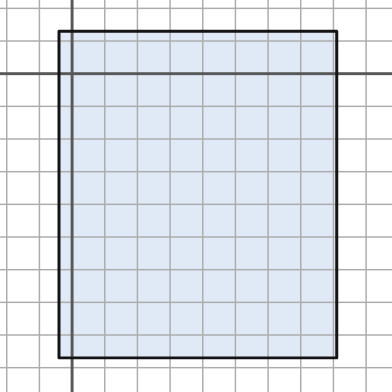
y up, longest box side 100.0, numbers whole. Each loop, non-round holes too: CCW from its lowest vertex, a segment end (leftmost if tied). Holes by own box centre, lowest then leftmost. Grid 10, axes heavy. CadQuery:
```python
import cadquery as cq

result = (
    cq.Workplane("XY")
    .moveTo(-4.0, -87.0)
    .lineTo(81.0, -87.0)
    .lineTo(81.0, 13.0)
    .lineTo(-4.0, 13.0)
    .close()
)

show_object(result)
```